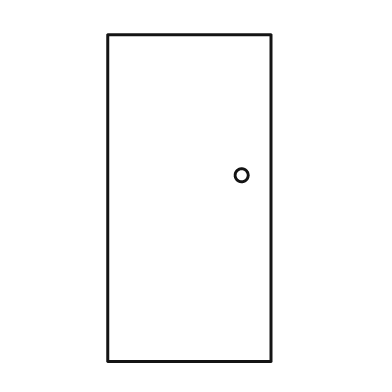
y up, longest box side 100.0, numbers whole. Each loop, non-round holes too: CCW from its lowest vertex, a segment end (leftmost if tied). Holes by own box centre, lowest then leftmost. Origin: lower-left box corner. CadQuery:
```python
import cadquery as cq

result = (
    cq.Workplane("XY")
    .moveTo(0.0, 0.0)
    .lineTo(50.0, 0.0)
    .lineTo(50.0, 100.0)
    .lineTo(0.0, 100.0)
    .close()
    .moveTo(41.0, 57.0)
    .circle(2.0)
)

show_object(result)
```